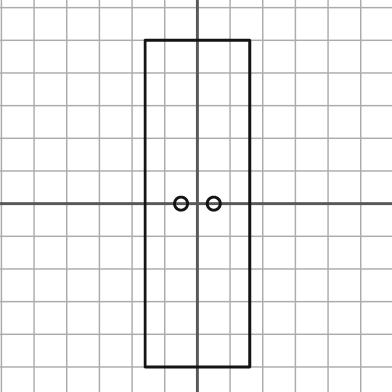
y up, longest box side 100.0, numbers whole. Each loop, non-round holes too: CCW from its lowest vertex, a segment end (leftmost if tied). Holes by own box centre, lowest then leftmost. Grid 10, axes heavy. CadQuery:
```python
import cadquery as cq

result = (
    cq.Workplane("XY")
    .moveTo(-16.0, -50.0)
    .lineTo(16.0, -50.0)
    .lineTo(16.0, 50.0)
    .lineTo(-16.0, 50.0)
    .close()
    .moveTo(-5.0, 0.0)
    .circle(2.0)
    .moveTo(5.0, 0.0)
    .circle(2.0)
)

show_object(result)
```